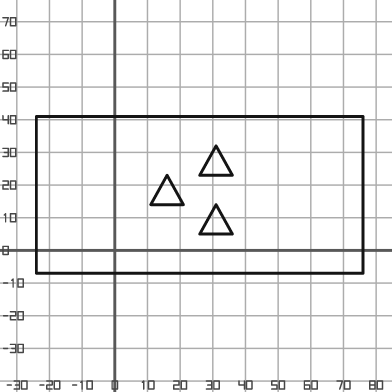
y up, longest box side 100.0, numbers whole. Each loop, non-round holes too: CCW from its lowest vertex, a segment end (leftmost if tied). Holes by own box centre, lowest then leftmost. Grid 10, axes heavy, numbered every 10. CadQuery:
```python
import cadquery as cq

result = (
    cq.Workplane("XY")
    .moveTo(-24.0, -7.0)
    .lineTo(76.0, -7.0)
    .lineTo(76.0, 41.0)
    .lineTo(-24.0, 41.0)
    .close()
    .moveTo(26.0, 5.0)
    .lineTo(36.0, 5.0)
    .lineTo(31.0, 14.0)
    .close()
    .moveTo(11.0, 14.0)
    .lineTo(21.0, 14.0)
    .lineTo(16.0, 23.0)
    .close()
    .moveTo(26.0, 23.0)
    .lineTo(36.0, 23.0)
    .lineTo(31.0, 32.0)
    .close()
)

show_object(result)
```